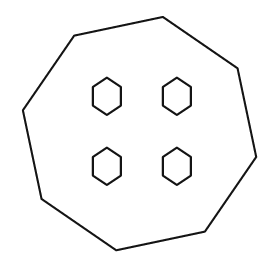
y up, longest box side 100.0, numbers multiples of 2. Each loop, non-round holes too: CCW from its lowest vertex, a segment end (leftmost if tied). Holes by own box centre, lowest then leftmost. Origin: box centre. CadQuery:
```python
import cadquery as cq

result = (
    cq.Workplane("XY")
    .moveTo(-10.0, -50.0)
    .lineTo(28.0, -42.0)
    .lineTo(50.0, -10.0)
    .lineTo(42.0, 28.0)
    .lineTo(10.0, 50.0)
    .lineTo(-28.0, 42.0)
    .lineTo(-50.0, 10.0)
    .lineTo(-42.0, -28.0)
    .close()
    .moveTo(-14.0, -22.0)
    .lineTo(-8.0, -18.0)
    .lineTo(-8.0, -10.0)
    .lineTo(-14.0, -6.0)
    .lineTo(-20.0, -10.0)
    .lineTo(-20.0, -18.0)
    .close()
    .moveTo(16.0, -22.0)
    .lineTo(22.0, -18.0)
    .lineTo(22.0, -10.0)
    .lineTo(16.0, -6.0)
    .lineTo(10.0, -10.0)
    .lineTo(10.0, -18.0)
    .close()
    .moveTo(-14.0, 8.0)
    .lineTo(-8.0, 12.0)
    .lineTo(-8.0, 20.0)
    .lineTo(-14.0, 24.0)
    .lineTo(-20.0, 20.0)
    .lineTo(-20.0, 12.0)
    .close()
    .moveTo(16.0, 8.0)
    .lineTo(22.0, 12.0)
    .lineTo(22.0, 20.0)
    .lineTo(16.0, 24.0)
    .lineTo(10.0, 20.0)
    .lineTo(10.0, 12.0)
    .close()
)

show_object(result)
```